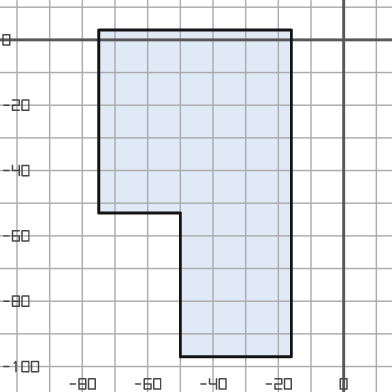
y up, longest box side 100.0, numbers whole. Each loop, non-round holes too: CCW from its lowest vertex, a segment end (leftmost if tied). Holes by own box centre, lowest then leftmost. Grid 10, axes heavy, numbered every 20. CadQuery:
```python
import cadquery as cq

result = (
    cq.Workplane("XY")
    .moveTo(-50.0, -97.0)
    .lineTo(-16.0, -97.0)
    .lineTo(-16.0, 3.0)
    .lineTo(-75.0, 3.0)
    .lineTo(-75.0, -53.0)
    .lineTo(-50.0, -53.0)
    .close()
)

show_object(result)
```